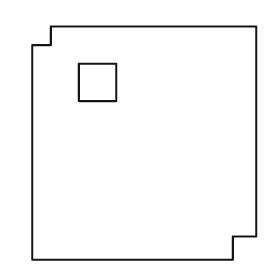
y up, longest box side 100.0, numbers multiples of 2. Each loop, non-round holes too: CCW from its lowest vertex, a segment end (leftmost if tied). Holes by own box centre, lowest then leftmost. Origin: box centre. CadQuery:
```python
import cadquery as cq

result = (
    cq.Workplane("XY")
    .moveTo(-48.0, -50.0)
    .lineTo(38.0, -50.0)
    .lineTo(38.0, -40.0)
    .lineTo(48.0, -40.0)
    .lineTo(48.0, 50.0)
    .lineTo(-40.0, 50.0)
    .lineTo(-40.0, 42.0)
    .lineTo(-48.0, 42.0)
    .close()
    .moveTo(-28.0, 18.0)
    .lineTo(-12.0, 18.0)
    .lineTo(-12.0, 34.0)
    .lineTo(-28.0, 34.0)
    .close()
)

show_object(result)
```